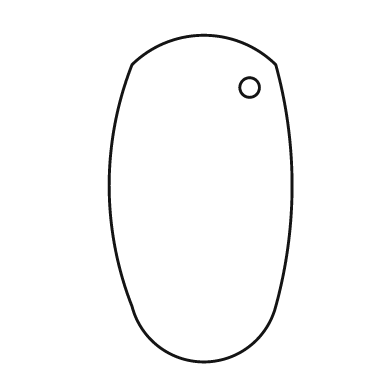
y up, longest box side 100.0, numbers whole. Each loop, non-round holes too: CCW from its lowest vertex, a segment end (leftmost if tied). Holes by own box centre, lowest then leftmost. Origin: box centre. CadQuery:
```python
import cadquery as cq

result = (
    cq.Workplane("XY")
    .moveTo(-21.0, -33.0)
    .threePointArc((1.0, -50.0), (23.0, -33.0))
    .threePointArc((28.0, 4.0), (23.0, 41.0))
    .threePointArc((1.0, 50.0), (-21.0, 41.0))
    .threePointArc((-28.0, 4.0), (-21.0, -33.0))
    .close()
    .moveTo(15.0, 34.0)
    .circle(3.0)
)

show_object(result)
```